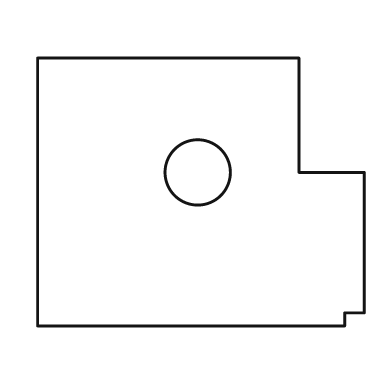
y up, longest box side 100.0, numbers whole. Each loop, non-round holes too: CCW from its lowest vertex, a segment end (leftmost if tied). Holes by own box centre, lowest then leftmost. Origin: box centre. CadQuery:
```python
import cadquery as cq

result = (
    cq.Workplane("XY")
    .moveTo(-50.0, -41.0)
    .lineTo(44.0, -41.0)
    .lineTo(44.0, -37.0)
    .lineTo(50.0, -37.0)
    .lineTo(50.0, 6.0)
    .lineTo(30.0, 6.0)
    .lineTo(30.0, 41.0)
    .lineTo(-50.0, 41.0)
    .close()
    .moveTo(-1.0, 6.0)
    .circle(10.0)
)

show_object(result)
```